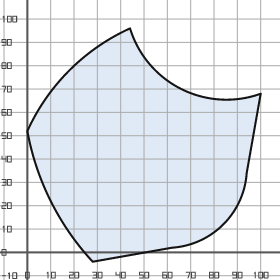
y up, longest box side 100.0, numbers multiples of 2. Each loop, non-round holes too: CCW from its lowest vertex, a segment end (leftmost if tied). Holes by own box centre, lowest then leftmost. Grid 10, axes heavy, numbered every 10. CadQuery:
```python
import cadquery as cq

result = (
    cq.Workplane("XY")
    .moveTo(28.0, -4.0)
    .lineTo(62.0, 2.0)
    .threePointArc((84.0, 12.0), (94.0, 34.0))
    .lineTo(100.0, 68.0)
    .threePointArc((66.0, 70.0), (44.0, 96.0))
    .threePointArc((18.0, 78.0), (0.0, 52.0))
    .threePointArc((10.0, 22.0), (28.0, -4.0))
    .close()
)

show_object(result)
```